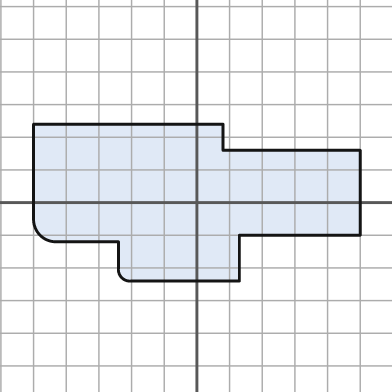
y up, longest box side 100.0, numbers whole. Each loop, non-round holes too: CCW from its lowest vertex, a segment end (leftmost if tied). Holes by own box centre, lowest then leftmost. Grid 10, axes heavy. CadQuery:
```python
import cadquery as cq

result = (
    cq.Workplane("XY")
    .moveTo(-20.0, -24.0)
    .lineTo(13.0, -24.0)
    .lineTo(13.0, -10.0)
    .lineTo(50.0, -10.0)
    .lineTo(50.0, 16.0)
    .lineTo(8.0, 16.0)
    .lineTo(8.0, 24.0)
    .lineTo(-50.0, 24.0)
    .lineTo(-50.0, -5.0)
    .threePointArc((-48.0, -10.0), (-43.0, -12.0))
    .lineTo(-24.0, -12.0)
    .lineTo(-24.0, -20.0)
    .threePointArc((-23.0, -23.0), (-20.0, -24.0))
    .close()
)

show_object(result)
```